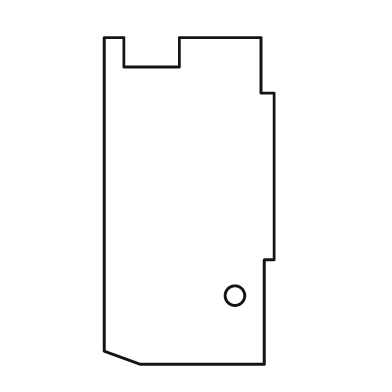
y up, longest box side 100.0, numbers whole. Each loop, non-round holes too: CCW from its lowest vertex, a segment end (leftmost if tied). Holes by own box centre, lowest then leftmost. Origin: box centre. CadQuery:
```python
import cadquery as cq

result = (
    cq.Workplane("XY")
    .moveTo(-15.0, -50.0)
    .lineTo(23.0, -50.0)
    .lineTo(23.0, -18.0)
    .lineTo(26.0, -18.0)
    .lineTo(26.0, 33.0)
    .lineTo(22.0, 33.0)
    .lineTo(22.0, 50.0)
    .lineTo(-3.0, 50.0)
    .lineTo(-3.0, 41.0)
    .lineTo(-20.0, 41.0)
    .lineTo(-20.0, 50.0)
    .lineTo(-26.0, 50.0)
    .lineTo(-26.0, -46.0)
    .close()
    .moveTo(14.0, -29.0)
    .circle(3.0)
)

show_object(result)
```